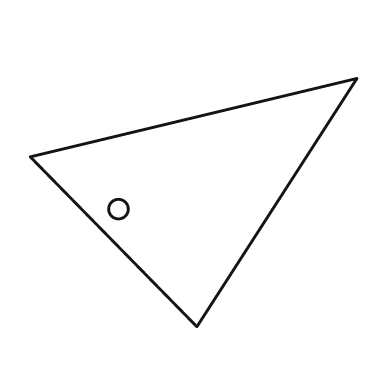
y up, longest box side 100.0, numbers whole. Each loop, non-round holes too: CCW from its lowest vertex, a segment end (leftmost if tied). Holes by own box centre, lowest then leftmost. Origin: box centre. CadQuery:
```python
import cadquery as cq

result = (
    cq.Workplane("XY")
    .moveTo(1.0, -38.0)
    .lineTo(50.0, 38.0)
    .lineTo(-50.0, 14.0)
    .close()
    .moveTo(-23.0, -2.0)
    .circle(3.0)
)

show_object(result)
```